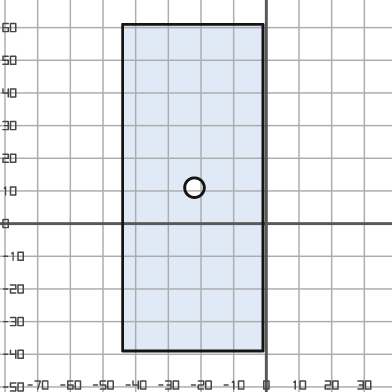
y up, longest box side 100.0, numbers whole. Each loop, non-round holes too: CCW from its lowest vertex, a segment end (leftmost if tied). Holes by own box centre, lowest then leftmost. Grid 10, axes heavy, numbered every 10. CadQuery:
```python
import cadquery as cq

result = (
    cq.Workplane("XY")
    .moveTo(-44.0, -39.0)
    .lineTo(-1.0, -39.0)
    .lineTo(-1.0, 61.0)
    .lineTo(-44.0, 61.0)
    .close()
    .moveTo(-22.0, 11.0)
    .circle(3.0)
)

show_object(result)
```